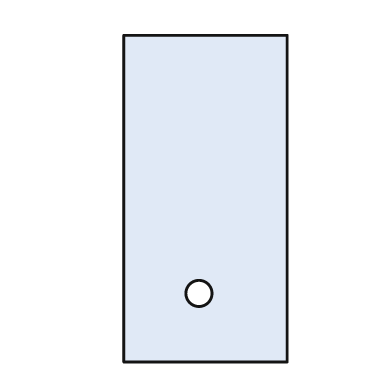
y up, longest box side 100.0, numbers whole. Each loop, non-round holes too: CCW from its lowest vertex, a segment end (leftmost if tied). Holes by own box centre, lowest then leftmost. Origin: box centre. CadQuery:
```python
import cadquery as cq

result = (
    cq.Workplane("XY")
    .moveTo(-25.0, -50.0)
    .lineTo(25.0, -50.0)
    .lineTo(25.0, 50.0)
    .lineTo(-25.0, 50.0)
    .close()
    .moveTo(-2.0, -29.0)
    .circle(4.0)
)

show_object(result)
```